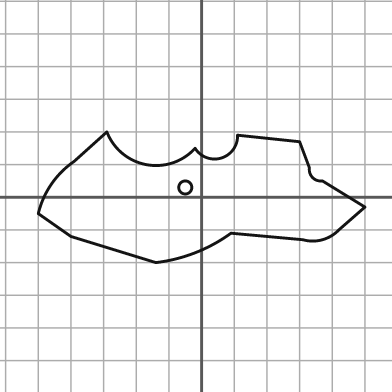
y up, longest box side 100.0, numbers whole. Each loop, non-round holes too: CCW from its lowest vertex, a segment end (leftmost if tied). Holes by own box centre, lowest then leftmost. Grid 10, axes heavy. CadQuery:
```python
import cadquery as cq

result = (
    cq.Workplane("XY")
    .moveTo(-14.0, -20.0)
    .threePointArc((-2.0, -17.0), (9.0, -11.0))
    .lineTo(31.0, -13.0)
    .threePointArc((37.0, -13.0), (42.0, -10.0))
    .lineTo(50.0, -3.0)
    .lineTo(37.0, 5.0)
    .threePointArc((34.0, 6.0), (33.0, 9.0))
    .lineTo(30.0, 17.0)
    .lineTo(11.0, 19.0)
    .threePointArc((6.0, 12.0), (-2.0, 15.0))
    .threePointArc((-17.0, 10.0), (-29.0, 20.0))
    .lineTo(-39.0, 11.0)
    .threePointArc((-46.0, 4.0), (-50.0, -5.0))
    .lineTo(-40.0, -12.0)
    .close()
    .moveTo(-5.0, 3.0)
    .circle(2.0)
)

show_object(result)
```